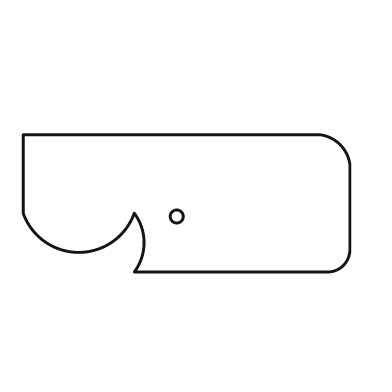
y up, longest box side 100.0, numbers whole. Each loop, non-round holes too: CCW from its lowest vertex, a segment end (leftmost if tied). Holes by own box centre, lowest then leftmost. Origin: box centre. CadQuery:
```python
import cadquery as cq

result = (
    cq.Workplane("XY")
    .moveTo(-16.0, -21.0)
    .lineTo(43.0, -21.0)
    .threePointArc((48.0, -19.0), (50.0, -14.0))
    .lineTo(50.0, 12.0)
    .threePointArc((47.0, 18.0), (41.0, 21.0))
    .lineTo(-50.0, 21.0)
    .lineTo(-50.0, -3.0)
    .threePointArc((-33.0, -15.0), (-16.0, -3.0))
    .threePointArc((-13.0, -12.0), (-16.0, -21.0))
    .close()
    .moveTo(-3.0, -4.0)
    .circle(2.0)
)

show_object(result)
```